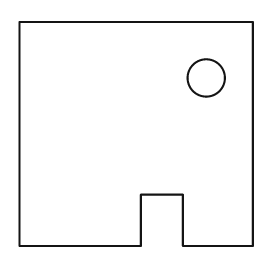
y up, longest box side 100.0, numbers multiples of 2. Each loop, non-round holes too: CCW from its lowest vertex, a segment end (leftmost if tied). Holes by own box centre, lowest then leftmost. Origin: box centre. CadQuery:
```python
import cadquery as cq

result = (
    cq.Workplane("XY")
    .moveTo(-50.0, -48.0)
    .lineTo(2.0, -48.0)
    .lineTo(2.0, -26.0)
    .lineTo(20.0, -26.0)
    .lineTo(20.0, -48.0)
    .lineTo(50.0, -48.0)
    .lineTo(50.0, 48.0)
    .lineTo(-50.0, 48.0)
    .close()
    .moveTo(30.0, 24.0)
    .circle(8.0)
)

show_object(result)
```